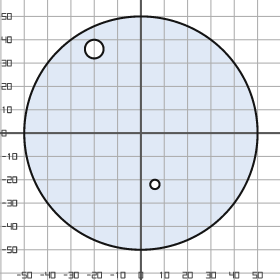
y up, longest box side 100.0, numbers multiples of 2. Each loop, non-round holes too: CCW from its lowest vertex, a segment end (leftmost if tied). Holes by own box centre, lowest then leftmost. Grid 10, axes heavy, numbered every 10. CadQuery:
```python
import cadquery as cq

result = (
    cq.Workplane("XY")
    .moveTo(0.0, 0.0)
    .circle(50.0)
    .moveTo(6.0, -22.0)
    .circle(2.0)
    .moveTo(-20.0, 36.0)
    .circle(4.0)
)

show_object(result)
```